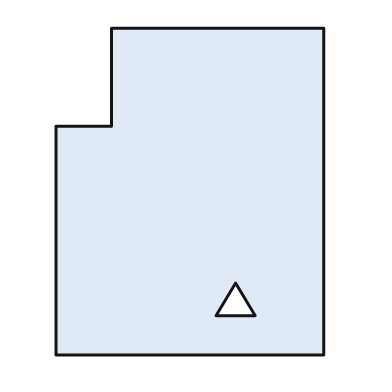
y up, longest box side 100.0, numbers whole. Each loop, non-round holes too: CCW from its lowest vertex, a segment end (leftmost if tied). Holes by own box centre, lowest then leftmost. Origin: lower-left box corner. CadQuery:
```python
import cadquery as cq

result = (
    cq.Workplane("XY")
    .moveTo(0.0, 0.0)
    .lineTo(82.0, 0.0)
    .lineTo(82.0, 100.0)
    .lineTo(17.0, 100.0)
    .lineTo(17.0, 70.0)
    .lineTo(0.0, 70.0)
    .close()
    .moveTo(49.0, 12.0)
    .lineTo(61.0, 12.0)
    .lineTo(55.0, 22.0)
    .close()
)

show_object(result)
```